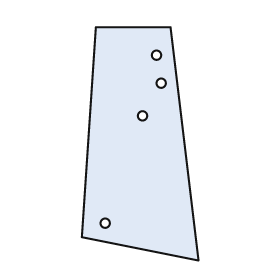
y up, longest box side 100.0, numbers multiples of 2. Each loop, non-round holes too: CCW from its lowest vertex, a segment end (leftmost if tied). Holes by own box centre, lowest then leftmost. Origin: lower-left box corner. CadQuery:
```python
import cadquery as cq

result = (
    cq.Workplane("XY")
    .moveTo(50.0, 0.0)
    .lineTo(38.0, 100.0)
    .lineTo(6.0, 100.0)
    .lineTo(0.0, 10.0)
    .close()
    .moveTo(10.0, 16.0)
    .circle(2.0)
    .moveTo(26.0, 62.0)
    .circle(2.0)
    .moveTo(34.0, 76.0)
    .circle(2.0)
    .moveTo(32.0, 88.0)
    .circle(2.0)
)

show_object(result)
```